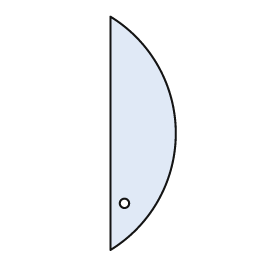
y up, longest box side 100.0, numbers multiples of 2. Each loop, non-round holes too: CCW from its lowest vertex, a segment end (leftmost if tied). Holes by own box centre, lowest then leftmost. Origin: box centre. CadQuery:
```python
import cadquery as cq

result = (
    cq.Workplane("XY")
    .moveTo(-14.0, -50.0)
    .threePointArc((14.0, 0.0), (-14.0, 50.0))
    .close()
    .moveTo(-8.0, -30.0)
    .circle(2.0)
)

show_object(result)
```